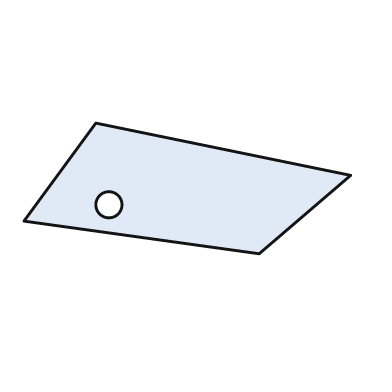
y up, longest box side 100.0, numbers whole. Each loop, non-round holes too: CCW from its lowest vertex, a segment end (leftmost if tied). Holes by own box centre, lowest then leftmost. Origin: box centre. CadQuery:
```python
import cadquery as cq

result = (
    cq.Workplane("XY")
    .moveTo(22.0, -20.0)
    .lineTo(50.0, 4.0)
    .lineTo(-28.0, 20.0)
    .lineTo(-50.0, -10.0)
    .close()
    .moveTo(-24.0, -5.0)
    .circle(4.0)
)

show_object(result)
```